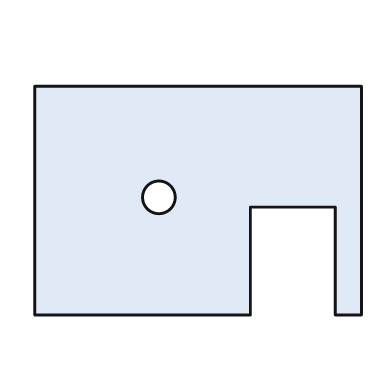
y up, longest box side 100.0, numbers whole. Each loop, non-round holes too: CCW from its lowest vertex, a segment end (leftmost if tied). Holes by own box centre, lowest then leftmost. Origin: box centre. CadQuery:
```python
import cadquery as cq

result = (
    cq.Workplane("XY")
    .moveTo(-50.0, -35.0)
    .lineTo(16.0, -35.0)
    .lineTo(16.0, -2.0)
    .lineTo(42.0, -2.0)
    .lineTo(42.0, -35.0)
    .lineTo(50.0, -35.0)
    .lineTo(50.0, 35.0)
    .lineTo(-50.0, 35.0)
    .close()
    .moveTo(-12.0, 1.0)
    .circle(5.0)
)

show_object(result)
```